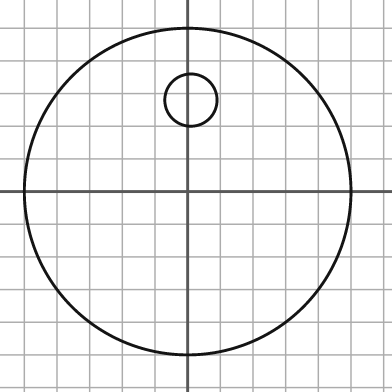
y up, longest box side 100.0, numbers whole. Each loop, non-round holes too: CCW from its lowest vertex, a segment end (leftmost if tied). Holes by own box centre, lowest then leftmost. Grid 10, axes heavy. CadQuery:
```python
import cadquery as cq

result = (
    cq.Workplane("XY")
    .moveTo(0.0, 0.0)
    .circle(50.0)
    .moveTo(1.0, 28.0)
    .circle(8.0)
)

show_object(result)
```